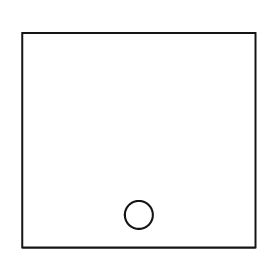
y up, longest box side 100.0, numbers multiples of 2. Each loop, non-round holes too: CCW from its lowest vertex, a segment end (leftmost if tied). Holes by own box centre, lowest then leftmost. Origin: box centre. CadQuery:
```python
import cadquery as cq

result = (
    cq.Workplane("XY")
    .moveTo(-50.0, -46.0)
    .lineTo(50.0, -46.0)
    .lineTo(50.0, 46.0)
    .lineTo(-50.0, 46.0)
    .close()
    .moveTo(0.0, -32.0)
    .circle(6.0)
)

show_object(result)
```